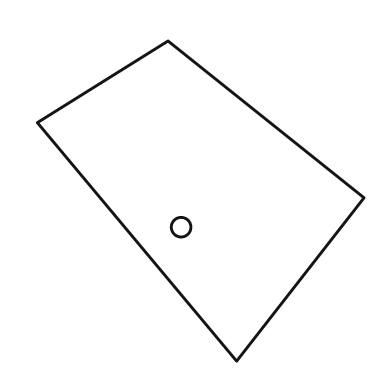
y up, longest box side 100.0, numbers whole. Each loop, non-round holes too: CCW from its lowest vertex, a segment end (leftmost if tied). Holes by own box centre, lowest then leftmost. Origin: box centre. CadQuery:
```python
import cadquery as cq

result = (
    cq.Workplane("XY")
    .moveTo(11.0, -49.0)
    .lineTo(50.0, 1.0)
    .lineTo(-10.0, 49.0)
    .lineTo(-50.0, 24.0)
    .close()
    .moveTo(-6.0, -8.0)
    .circle(3.0)
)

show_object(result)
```